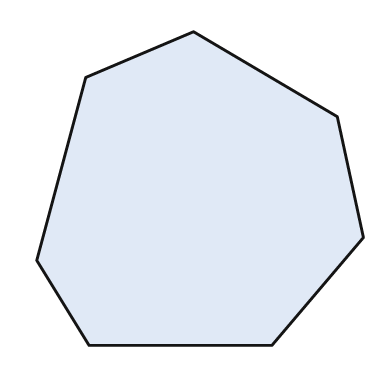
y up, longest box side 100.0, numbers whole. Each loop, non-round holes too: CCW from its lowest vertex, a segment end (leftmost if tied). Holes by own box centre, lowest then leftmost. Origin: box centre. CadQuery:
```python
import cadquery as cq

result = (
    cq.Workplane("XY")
    .moveTo(-34.0, -48.0)
    .lineTo(22.0, -48.0)
    .lineTo(50.0, -15.0)
    .lineTo(42.0, 22.0)
    .lineTo(-2.0, 48.0)
    .lineTo(-35.0, 34.0)
    .lineTo(-50.0, -22.0)
    .close()
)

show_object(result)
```